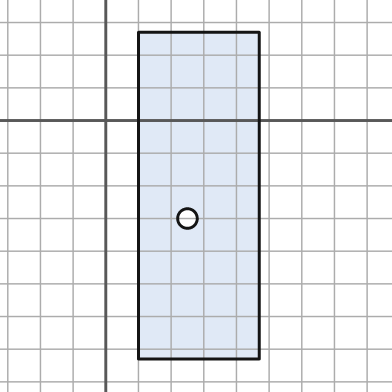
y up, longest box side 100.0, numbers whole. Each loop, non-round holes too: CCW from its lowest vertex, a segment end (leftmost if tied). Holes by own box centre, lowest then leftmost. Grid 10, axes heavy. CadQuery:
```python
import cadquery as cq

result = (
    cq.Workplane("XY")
    .moveTo(10.0, -73.0)
    .lineTo(47.0, -73.0)
    .lineTo(47.0, 27.0)
    .lineTo(10.0, 27.0)
    .close()
    .moveTo(25.0, -30.0)
    .circle(3.0)
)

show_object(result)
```